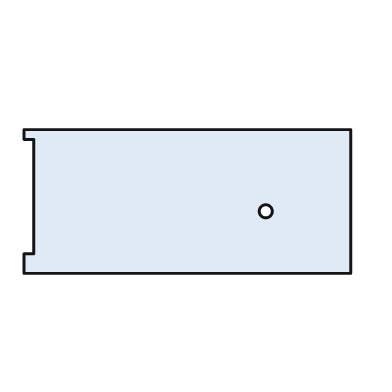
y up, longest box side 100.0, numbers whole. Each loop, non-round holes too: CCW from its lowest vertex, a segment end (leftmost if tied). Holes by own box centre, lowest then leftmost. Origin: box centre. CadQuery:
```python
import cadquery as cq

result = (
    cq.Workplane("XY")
    .moveTo(-50.0, -22.0)
    .lineTo(50.0, -22.0)
    .lineTo(50.0, 22.0)
    .lineTo(-50.0, 22.0)
    .lineTo(-50.0, 19.0)
    .lineTo(-47.0, 19.0)
    .lineTo(-47.0, -16.0)
    .lineTo(-50.0, -16.0)
    .close()
    .moveTo(24.0, -3.0)
    .circle(2.0)
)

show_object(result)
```